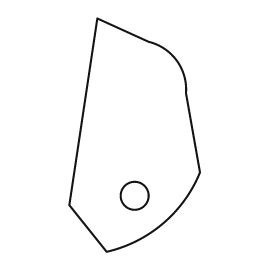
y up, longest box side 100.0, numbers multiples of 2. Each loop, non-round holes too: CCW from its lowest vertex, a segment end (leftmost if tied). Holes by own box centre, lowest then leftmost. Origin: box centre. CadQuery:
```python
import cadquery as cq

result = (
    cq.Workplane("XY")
    .moveTo(-12.0, -50.0)
    .threePointArc((12.0, -38.0), (28.0, -16.0))
    .lineTo(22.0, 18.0)
    .threePointArc((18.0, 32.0), (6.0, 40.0))
    .lineTo(-16.0, 50.0)
    .lineTo(-28.0, -30.0)
    .close()
    .moveTo(0.0, -26.0)
    .circle(6.0)
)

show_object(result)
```